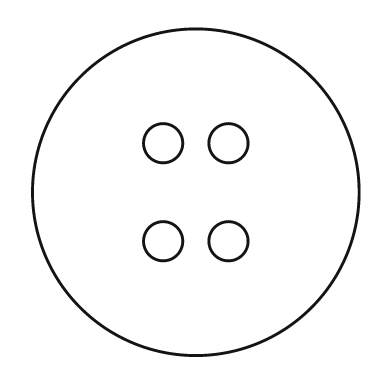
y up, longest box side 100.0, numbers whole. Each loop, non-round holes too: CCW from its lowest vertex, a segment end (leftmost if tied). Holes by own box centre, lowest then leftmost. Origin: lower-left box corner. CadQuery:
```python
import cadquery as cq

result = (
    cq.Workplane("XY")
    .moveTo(50.0, 50.0)
    .circle(50.0)
    .moveTo(40.0, 35.0)
    .circle(6.0)
    .moveTo(60.0, 35.0)
    .circle(6.0)
    .moveTo(40.0, 65.0)
    .circle(6.0)
    .moveTo(60.0, 65.0)
    .circle(6.0)
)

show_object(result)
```